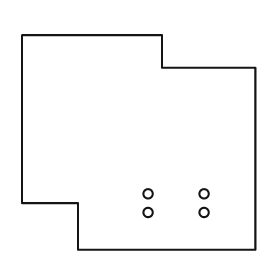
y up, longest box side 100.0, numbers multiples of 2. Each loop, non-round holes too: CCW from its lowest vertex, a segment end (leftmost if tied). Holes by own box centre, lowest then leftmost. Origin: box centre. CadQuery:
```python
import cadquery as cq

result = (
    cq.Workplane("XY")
    .moveTo(-26.0, -46.0)
    .lineTo(50.0, -46.0)
    .lineTo(50.0, 32.0)
    .lineTo(10.0, 32.0)
    .lineTo(10.0, 46.0)
    .lineTo(-50.0, 46.0)
    .lineTo(-50.0, -26.0)
    .lineTo(-26.0, -26.0)
    .close()
    .moveTo(4.0, -30.0)
    .circle(2.0)
    .moveTo(28.0, -30.0)
    .circle(2.0)
    .moveTo(4.0, -22.0)
    .circle(2.0)
    .moveTo(28.0, -22.0)
    .circle(2.0)
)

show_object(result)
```